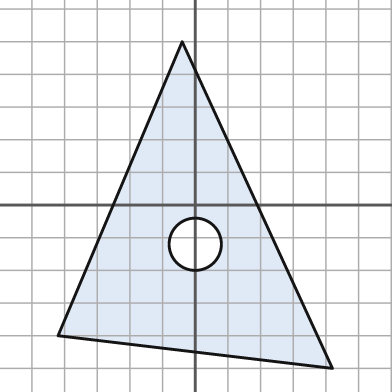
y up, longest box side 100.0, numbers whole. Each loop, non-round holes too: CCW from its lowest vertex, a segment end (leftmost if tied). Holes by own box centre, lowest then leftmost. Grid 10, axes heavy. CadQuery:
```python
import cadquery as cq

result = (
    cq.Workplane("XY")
    .moveTo(42.0, -50.0)
    .lineTo(-4.0, 50.0)
    .lineTo(-42.0, -40.0)
    .close()
    .moveTo(0.0, -12.0)
    .circle(8.0)
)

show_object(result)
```